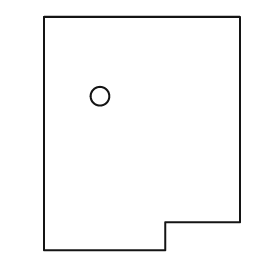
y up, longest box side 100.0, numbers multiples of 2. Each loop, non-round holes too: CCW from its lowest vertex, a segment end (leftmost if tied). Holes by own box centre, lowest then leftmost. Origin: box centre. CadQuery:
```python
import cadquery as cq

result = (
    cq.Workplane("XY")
    .moveTo(-42.0, -50.0)
    .lineTo(10.0, -50.0)
    .lineTo(10.0, -38.0)
    .lineTo(42.0, -38.0)
    .lineTo(42.0, 50.0)
    .lineTo(-42.0, 50.0)
    .close()
    .moveTo(-18.0, 16.0)
    .circle(4.0)
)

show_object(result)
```